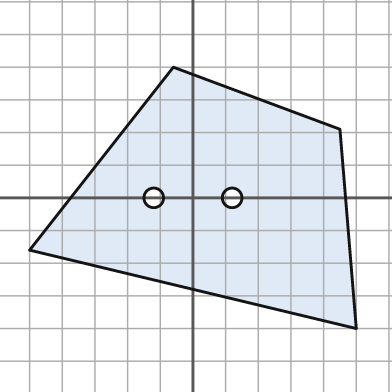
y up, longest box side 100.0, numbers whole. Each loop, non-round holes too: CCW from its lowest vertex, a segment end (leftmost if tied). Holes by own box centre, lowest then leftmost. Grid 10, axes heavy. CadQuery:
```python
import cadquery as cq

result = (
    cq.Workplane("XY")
    .moveTo(50.0, -40.0)
    .lineTo(45.0, 21.0)
    .lineTo(-6.0, 40.0)
    .lineTo(-50.0, -16.0)
    .close()
    .moveTo(-12.0, 0.0)
    .circle(3.0)
    .moveTo(12.0, 0.0)
    .circle(3.0)
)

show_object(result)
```